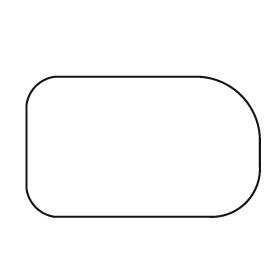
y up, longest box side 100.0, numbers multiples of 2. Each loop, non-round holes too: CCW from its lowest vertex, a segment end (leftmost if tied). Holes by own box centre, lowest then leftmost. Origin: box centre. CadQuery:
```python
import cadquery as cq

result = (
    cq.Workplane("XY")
    .moveTo(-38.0, -30.0)
    .lineTo(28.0, -30.0)
    .threePointArc((44.0, -24.0), (50.0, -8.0))
    .lineTo(50.0, 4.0)
    .threePointArc((42.0, 22.0), (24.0, 30.0))
    .lineTo(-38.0, 30.0)
    .threePointArc((-46.0, 26.0), (-50.0, 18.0))
    .lineTo(-50.0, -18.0)
    .threePointArc((-46.0, -26.0), (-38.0, -30.0))
    .close()
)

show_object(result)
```